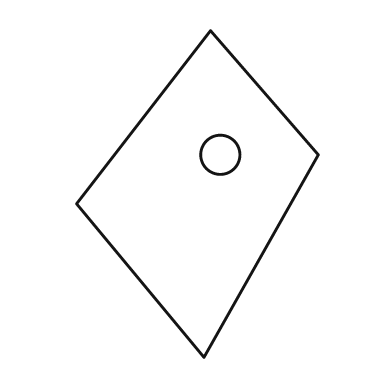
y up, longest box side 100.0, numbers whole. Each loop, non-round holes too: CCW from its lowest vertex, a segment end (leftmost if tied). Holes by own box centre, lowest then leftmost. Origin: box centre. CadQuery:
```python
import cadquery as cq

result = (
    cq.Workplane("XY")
    .moveTo(2.0, -50.0)
    .lineTo(37.0, 12.0)
    .lineTo(4.0, 50.0)
    .lineTo(-37.0, -3.0)
    .close()
    .moveTo(7.0, 12.0)
    .circle(6.0)
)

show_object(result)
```